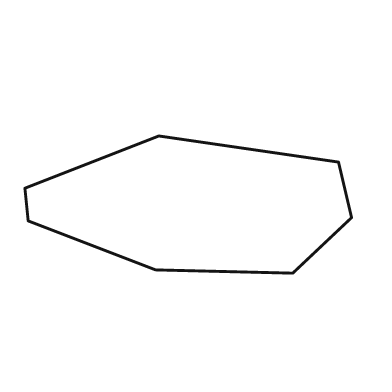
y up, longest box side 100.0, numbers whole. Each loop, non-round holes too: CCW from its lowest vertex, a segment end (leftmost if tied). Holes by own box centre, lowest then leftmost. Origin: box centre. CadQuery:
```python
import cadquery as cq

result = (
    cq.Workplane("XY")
    .moveTo(32.0, -21.0)
    .lineTo(50.0, -4.0)
    .lineTo(46.0, 13.0)
    .lineTo(-9.0, 21.0)
    .lineTo(-50.0, 5.0)
    .lineTo(-49.0, -5.0)
    .lineTo(-10.0, -20.0)
    .close()
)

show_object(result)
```